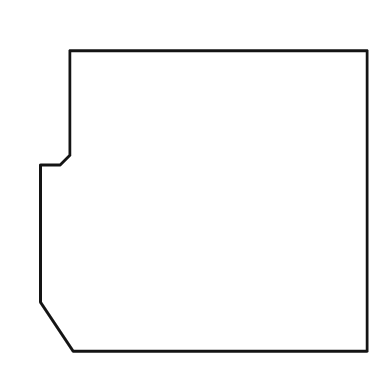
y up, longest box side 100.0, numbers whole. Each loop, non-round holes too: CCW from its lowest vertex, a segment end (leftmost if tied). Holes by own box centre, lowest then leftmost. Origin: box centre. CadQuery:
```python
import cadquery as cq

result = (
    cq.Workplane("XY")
    .moveTo(-40.0, -46.0)
    .lineTo(50.0, -46.0)
    .lineTo(50.0, 46.0)
    .lineTo(-41.0, 46.0)
    .lineTo(-41.0, 14.0)
    .lineTo(-44.0, 11.0)
    .lineTo(-50.0, 11.0)
    .lineTo(-50.0, -31.0)
    .close()
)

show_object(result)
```